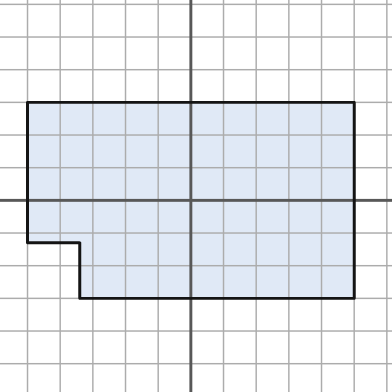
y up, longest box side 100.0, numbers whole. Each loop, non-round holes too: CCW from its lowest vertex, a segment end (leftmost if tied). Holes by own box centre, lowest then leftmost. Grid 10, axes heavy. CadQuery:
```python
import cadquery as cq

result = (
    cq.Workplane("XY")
    .moveTo(-34.0, -30.0)
    .lineTo(50.0, -30.0)
    .lineTo(50.0, 30.0)
    .lineTo(-50.0, 30.0)
    .lineTo(-50.0, -13.0)
    .lineTo(-34.0, -13.0)
    .close()
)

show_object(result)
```